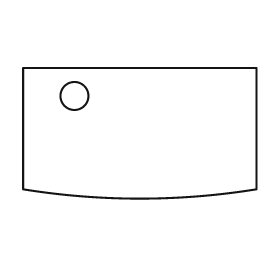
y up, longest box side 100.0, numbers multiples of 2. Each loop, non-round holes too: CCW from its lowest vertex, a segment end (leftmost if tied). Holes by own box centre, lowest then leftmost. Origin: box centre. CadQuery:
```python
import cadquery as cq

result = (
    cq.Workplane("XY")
    .moveTo(-50.0, -24.0)
    .threePointArc((0.0, -28.0), (50.0, -24.0))
    .lineTo(50.0, 28.0)
    .lineTo(-50.0, 28.0)
    .close()
    .moveTo(-28.0, 16.0)
    .circle(6.0)
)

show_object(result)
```